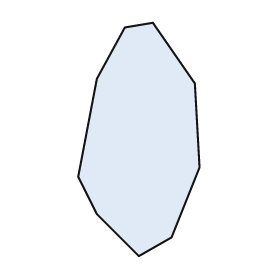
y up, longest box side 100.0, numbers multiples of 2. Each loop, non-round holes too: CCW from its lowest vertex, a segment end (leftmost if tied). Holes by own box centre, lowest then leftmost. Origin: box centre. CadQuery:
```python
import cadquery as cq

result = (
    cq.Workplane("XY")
    .moveTo(0.0, -50.0)
    .lineTo(14.0, -42.0)
    .lineTo(26.0, -12.0)
    .lineTo(24.0, 24.0)
    .lineTo(6.0, 50.0)
    .lineTo(-6.0, 48.0)
    .lineTo(-18.0, 26.0)
    .lineTo(-26.0, -16.0)
    .lineTo(-18.0, -32.0)
    .close()
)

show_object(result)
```